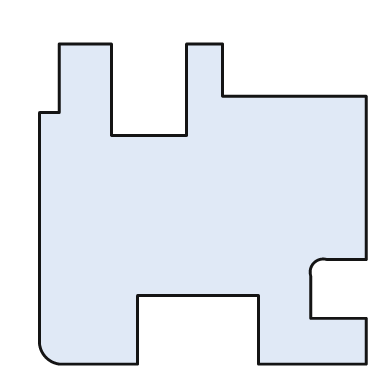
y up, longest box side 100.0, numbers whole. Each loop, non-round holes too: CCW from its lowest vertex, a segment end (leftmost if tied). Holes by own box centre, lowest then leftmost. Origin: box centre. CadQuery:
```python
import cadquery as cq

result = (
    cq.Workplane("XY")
    .moveTo(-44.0, -49.0)
    .lineTo(-20.0, -49.0)
    .lineTo(-20.0, -28.0)
    .lineTo(17.0, -28.0)
    .lineTo(17.0, -49.0)
    .lineTo(50.0, -49.0)
    .lineTo(50.0, -35.0)
    .lineTo(33.0, -35.0)
    .lineTo(33.0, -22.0)
    .threePointArc((34.0, -18.0), (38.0, -17.0))
    .lineTo(50.0, -17.0)
    .lineTo(50.0, 33.0)
    .lineTo(6.0, 33.0)
    .lineTo(6.0, 49.0)
    .lineTo(-5.0, 49.0)
    .lineTo(-5.0, 21.0)
    .lineTo(-28.0, 21.0)
    .lineTo(-28.0, 49.0)
    .lineTo(-44.0, 49.0)
    .lineTo(-44.0, 28.0)
    .lineTo(-50.0, 28.0)
    .lineTo(-50.0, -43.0)
    .threePointArc((-48.0, -47.0), (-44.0, -49.0))
    .close()
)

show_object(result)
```